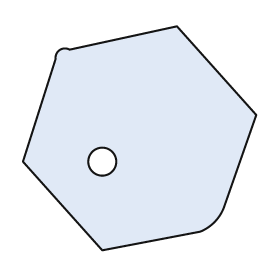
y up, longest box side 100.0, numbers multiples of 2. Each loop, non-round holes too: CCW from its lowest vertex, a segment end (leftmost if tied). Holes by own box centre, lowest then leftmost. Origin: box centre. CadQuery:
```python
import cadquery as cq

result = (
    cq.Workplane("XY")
    .moveTo(-16.0, -48.0)
    .lineTo(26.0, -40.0)
    .threePointArc((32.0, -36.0), (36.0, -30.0))
    .lineTo(50.0, 10.0)
    .lineTo(16.0, 48.0)
    .lineTo(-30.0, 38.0)
    .threePointArc((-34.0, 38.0), (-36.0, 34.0))
    .lineTo(-50.0, -10.0)
    .close()
    .moveTo(-16.0, -10.0)
    .circle(6.0)
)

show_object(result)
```